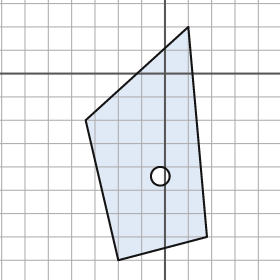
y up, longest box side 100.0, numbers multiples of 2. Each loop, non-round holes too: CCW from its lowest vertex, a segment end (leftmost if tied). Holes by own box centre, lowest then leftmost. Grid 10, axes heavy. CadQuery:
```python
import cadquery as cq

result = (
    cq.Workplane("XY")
    .moveTo(-20.0, -80.0)
    .lineTo(18.0, -70.0)
    .lineTo(10.0, 20.0)
    .lineTo(-34.0, -20.0)
    .close()
    .moveTo(-2.0, -44.0)
    .circle(4.0)
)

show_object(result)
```